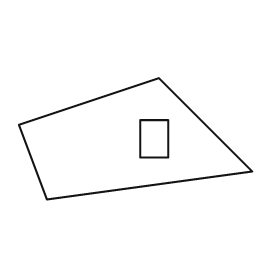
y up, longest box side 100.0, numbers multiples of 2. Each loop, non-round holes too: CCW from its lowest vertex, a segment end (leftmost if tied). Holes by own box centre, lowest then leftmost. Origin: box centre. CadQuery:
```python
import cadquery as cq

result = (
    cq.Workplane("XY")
    .moveTo(-38.0, -26.0)
    .lineTo(50.0, -14.0)
    .lineTo(10.0, 26.0)
    .lineTo(-50.0, 6.0)
    .close()
    .moveTo(2.0, -8.0)
    .lineTo(14.0, -8.0)
    .lineTo(14.0, 8.0)
    .lineTo(2.0, 8.0)
    .close()
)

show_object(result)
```